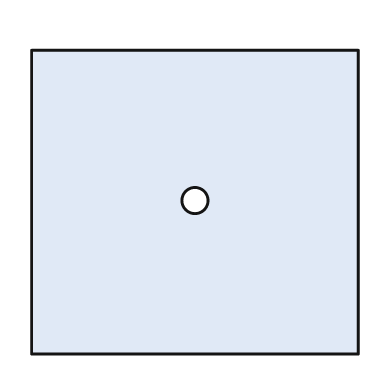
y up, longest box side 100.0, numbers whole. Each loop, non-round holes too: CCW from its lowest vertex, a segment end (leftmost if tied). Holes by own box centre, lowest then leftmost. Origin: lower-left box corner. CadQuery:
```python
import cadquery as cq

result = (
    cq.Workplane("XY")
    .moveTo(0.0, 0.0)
    .lineTo(100.0, 0.0)
    .lineTo(100.0, 93.0)
    .lineTo(0.0, 93.0)
    .close()
    .moveTo(50.0, 47.0)
    .circle(4.0)
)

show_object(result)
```